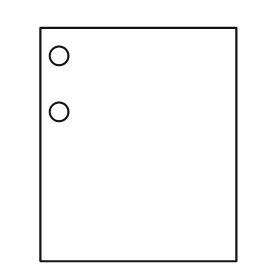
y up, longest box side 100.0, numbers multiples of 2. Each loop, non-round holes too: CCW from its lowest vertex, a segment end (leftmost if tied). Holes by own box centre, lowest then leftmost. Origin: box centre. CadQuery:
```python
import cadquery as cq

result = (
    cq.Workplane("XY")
    .moveTo(-42.0, -50.0)
    .lineTo(42.0, -50.0)
    .lineTo(42.0, 50.0)
    .lineTo(-42.0, 50.0)
    .close()
    .moveTo(-34.0, 14.0)
    .circle(4.0)
    .moveTo(-34.0, 38.0)
    .circle(4.0)
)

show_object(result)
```